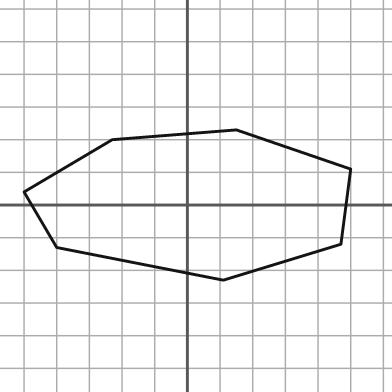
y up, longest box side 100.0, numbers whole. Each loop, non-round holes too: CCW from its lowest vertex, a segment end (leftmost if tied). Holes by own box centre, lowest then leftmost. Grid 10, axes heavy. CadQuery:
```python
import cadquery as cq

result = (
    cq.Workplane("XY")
    .moveTo(11.0, -23.0)
    .lineTo(47.0, -12.0)
    .lineTo(50.0, 11.0)
    .lineTo(15.0, 23.0)
    .lineTo(-23.0, 20.0)
    .lineTo(-50.0, 4.0)
    .lineTo(-40.0, -13.0)
    .close()
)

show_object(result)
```